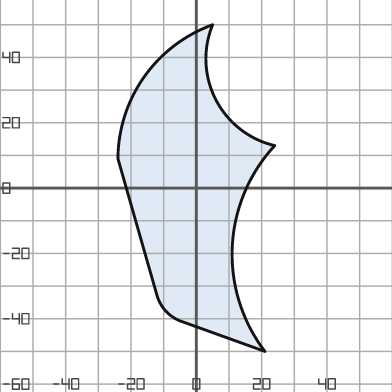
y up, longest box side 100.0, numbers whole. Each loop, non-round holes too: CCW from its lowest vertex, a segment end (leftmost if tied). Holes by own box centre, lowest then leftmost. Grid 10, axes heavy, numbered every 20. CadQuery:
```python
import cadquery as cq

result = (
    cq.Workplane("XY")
    .moveTo(21.0, -50.0)
    .threePointArc((11.0, -18.0), (24.0, 13.0))
    .threePointArc((6.0, 27.0), (5.0, 50.0))
    .threePointArc((-16.0, 34.0), (-24.0, 9.0))
    .lineTo(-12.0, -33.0)
    .threePointArc((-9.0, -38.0), (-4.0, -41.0))
    .close()
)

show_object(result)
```